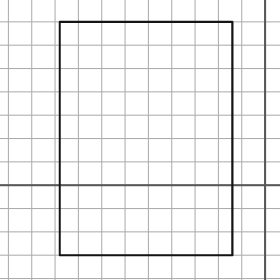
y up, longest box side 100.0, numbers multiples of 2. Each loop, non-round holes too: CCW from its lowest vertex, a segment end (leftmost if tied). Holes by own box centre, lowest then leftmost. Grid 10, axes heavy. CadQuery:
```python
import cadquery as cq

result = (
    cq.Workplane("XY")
    .moveTo(-88.0, -30.0)
    .lineTo(-14.0, -30.0)
    .lineTo(-14.0, 70.0)
    .lineTo(-88.0, 70.0)
    .close()
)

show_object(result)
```